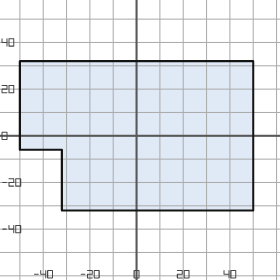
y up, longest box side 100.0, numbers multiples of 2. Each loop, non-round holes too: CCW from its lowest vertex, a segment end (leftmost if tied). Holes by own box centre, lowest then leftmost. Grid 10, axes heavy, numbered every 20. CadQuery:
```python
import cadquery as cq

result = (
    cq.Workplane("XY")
    .moveTo(-32.0, -32.0)
    .lineTo(50.0, -32.0)
    .lineTo(50.0, 32.0)
    .lineTo(-50.0, 32.0)
    .lineTo(-50.0, -6.0)
    .lineTo(-32.0, -6.0)
    .close()
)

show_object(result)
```